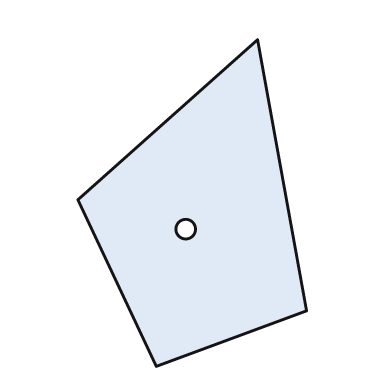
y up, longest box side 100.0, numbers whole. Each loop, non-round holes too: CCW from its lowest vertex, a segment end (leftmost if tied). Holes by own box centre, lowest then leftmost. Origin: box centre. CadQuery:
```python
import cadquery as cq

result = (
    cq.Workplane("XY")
    .moveTo(-11.0, -50.0)
    .lineTo(35.0, -33.0)
    .lineTo(20.0, 50.0)
    .lineTo(-35.0, 1.0)
    .close()
    .moveTo(-2.0, -8.0)
    .circle(3.0)
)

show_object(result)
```